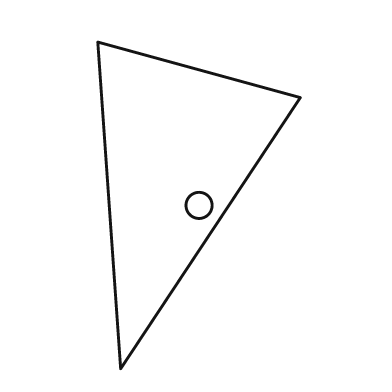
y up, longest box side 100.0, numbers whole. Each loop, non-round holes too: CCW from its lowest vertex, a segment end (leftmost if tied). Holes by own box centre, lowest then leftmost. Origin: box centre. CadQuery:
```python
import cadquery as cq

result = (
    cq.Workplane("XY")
    .moveTo(-24.0, -50.0)
    .lineTo(31.0, 33.0)
    .lineTo(-31.0, 50.0)
    .close()
    .moveTo(0.0, 0.0)
    .circle(4.0)
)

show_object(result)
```